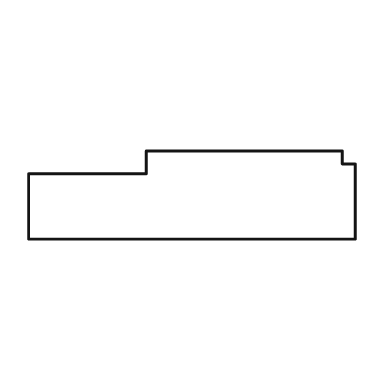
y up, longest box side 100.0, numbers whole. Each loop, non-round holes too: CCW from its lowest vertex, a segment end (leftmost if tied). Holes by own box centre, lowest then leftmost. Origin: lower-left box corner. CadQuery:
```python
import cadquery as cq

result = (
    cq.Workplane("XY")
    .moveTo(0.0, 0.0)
    .lineTo(100.0, 0.0)
    .lineTo(100.0, 23.0)
    .lineTo(96.0, 23.0)
    .lineTo(96.0, 27.0)
    .lineTo(36.0, 27.0)
    .lineTo(36.0, 20.0)
    .lineTo(0.0, 20.0)
    .close()
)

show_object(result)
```